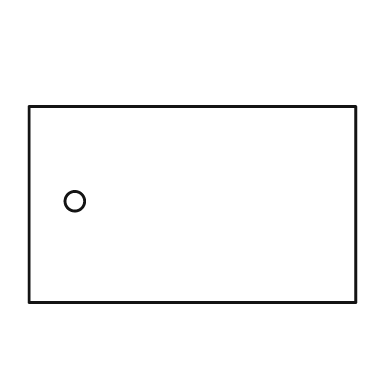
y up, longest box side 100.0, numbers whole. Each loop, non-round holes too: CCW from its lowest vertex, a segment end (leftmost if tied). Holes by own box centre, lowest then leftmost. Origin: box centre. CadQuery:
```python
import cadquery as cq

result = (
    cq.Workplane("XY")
    .moveTo(-50.0, -30.0)
    .lineTo(50.0, -30.0)
    .lineTo(50.0, 30.0)
    .lineTo(-50.0, 30.0)
    .close()
    .moveTo(-36.0, 1.0)
    .circle(3.0)
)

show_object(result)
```